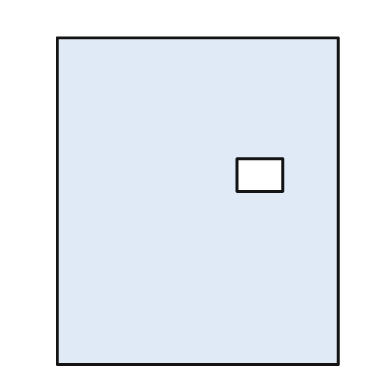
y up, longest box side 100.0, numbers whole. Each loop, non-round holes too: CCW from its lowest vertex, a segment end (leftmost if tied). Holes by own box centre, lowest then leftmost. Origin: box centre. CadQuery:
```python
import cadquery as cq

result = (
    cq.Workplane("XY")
    .moveTo(-43.0, -50.0)
    .lineTo(43.0, -50.0)
    .lineTo(43.0, 50.0)
    .lineTo(-43.0, 50.0)
    .close()
    .moveTo(12.0, 3.0)
    .lineTo(26.0, 3.0)
    .lineTo(26.0, 13.0)
    .lineTo(12.0, 13.0)
    .close()
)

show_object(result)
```